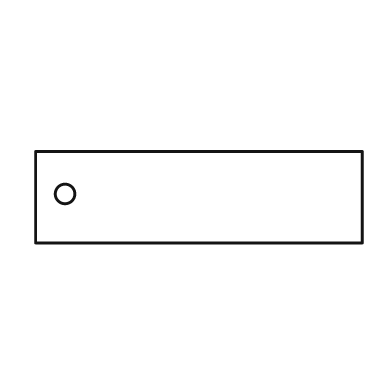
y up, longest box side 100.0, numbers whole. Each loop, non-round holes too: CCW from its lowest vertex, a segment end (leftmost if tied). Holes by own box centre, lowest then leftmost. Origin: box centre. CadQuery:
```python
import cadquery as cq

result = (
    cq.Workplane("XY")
    .moveTo(-50.0, -14.0)
    .lineTo(50.0, -14.0)
    .lineTo(50.0, 14.0)
    .lineTo(-50.0, 14.0)
    .close()
    .moveTo(-41.0, 1.0)
    .circle(3.0)
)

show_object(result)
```